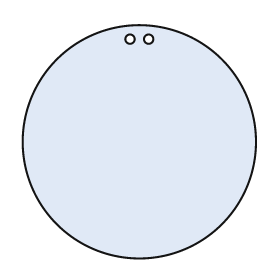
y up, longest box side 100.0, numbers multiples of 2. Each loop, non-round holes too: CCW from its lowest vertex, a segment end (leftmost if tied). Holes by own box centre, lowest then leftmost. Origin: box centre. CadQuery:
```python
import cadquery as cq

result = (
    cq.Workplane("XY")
    .moveTo(0.0, 0.0)
    .circle(50.0)
    .moveTo(-4.0, 44.0)
    .circle(2.0)
    .moveTo(4.0, 44.0)
    .circle(2.0)
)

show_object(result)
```